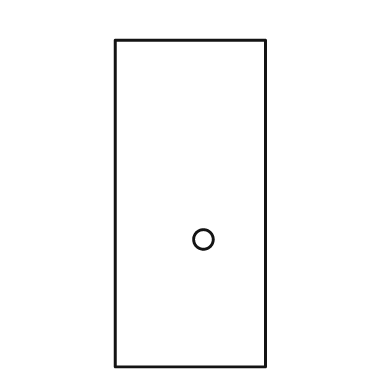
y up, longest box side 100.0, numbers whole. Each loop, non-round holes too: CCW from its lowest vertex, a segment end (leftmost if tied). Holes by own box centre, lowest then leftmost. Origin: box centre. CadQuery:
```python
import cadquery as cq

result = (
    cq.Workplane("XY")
    .moveTo(-23.0, -50.0)
    .lineTo(23.0, -50.0)
    .lineTo(23.0, 50.0)
    .lineTo(-23.0, 50.0)
    .close()
    .moveTo(4.0, -11.0)
    .circle(3.0)
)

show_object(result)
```